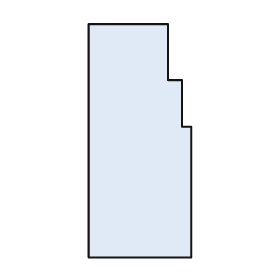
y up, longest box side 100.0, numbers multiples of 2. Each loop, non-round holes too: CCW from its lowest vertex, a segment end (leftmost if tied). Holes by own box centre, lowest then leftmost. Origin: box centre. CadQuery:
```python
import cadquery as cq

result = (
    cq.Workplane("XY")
    .moveTo(-22.0, -50.0)
    .lineTo(22.0, -50.0)
    .lineTo(22.0, 6.0)
    .lineTo(18.0, 6.0)
    .lineTo(18.0, 26.0)
    .lineTo(12.0, 26.0)
    .lineTo(12.0, 50.0)
    .lineTo(-22.0, 50.0)
    .close()
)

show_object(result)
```